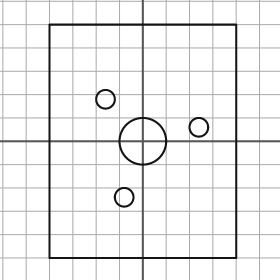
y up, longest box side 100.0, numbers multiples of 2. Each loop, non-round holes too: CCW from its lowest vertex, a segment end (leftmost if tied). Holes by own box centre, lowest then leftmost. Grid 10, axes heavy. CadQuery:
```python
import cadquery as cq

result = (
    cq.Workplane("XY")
    .moveTo(-40.0, -50.0)
    .lineTo(40.0, -50.0)
    .lineTo(40.0, 50.0)
    .lineTo(-40.0, 50.0)
    .close()
    .moveTo(-8.0, -24.0)
    .circle(4.0)
    .moveTo(0.0, 0.0)
    .circle(10.0)
    .moveTo(24.0, 6.0)
    .circle(4.0)
    .moveTo(-16.0, 18.0)
    .circle(4.0)
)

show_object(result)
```